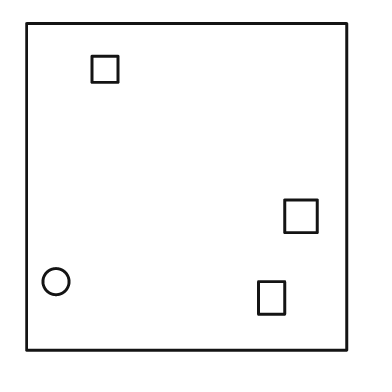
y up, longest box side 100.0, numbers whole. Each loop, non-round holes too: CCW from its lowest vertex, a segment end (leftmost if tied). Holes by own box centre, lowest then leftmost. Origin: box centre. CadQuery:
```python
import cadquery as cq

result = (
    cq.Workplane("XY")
    .moveTo(-49.0, -50.0)
    .lineTo(49.0, -50.0)
    .lineTo(49.0, 50.0)
    .lineTo(-49.0, 50.0)
    .close()
    .moveTo(22.0, -39.0)
    .lineTo(30.0, -39.0)
    .lineTo(30.0, -29.0)
    .lineTo(22.0, -29.0)
    .close()
    .moveTo(-40.0, -29.0)
    .circle(4.0)
    .moveTo(30.0, -14.0)
    .lineTo(40.0, -14.0)
    .lineTo(40.0, -4.0)
    .lineTo(30.0, -4.0)
    .close()
    .moveTo(-29.0, 32.0)
    .lineTo(-21.0, 32.0)
    .lineTo(-21.0, 40.0)
    .lineTo(-29.0, 40.0)
    .close()
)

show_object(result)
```